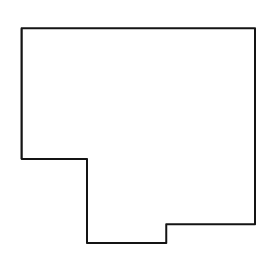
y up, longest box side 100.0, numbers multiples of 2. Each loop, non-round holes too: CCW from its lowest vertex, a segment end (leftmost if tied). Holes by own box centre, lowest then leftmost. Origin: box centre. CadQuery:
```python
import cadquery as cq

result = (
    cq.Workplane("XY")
    .moveTo(-22.0, -46.0)
    .lineTo(12.0, -46.0)
    .lineTo(12.0, -38.0)
    .lineTo(50.0, -38.0)
    .lineTo(50.0, 46.0)
    .lineTo(-50.0, 46.0)
    .lineTo(-50.0, -10.0)
    .lineTo(-22.0, -10.0)
    .close()
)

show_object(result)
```